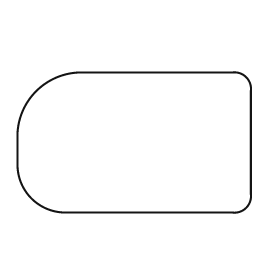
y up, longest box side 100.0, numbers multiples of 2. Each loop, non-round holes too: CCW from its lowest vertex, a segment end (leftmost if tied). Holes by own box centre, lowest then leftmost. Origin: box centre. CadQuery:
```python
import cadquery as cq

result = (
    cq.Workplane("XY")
    .moveTo(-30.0, -30.0)
    .lineTo(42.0, -30.0)
    .threePointArc((48.0, -28.0), (50.0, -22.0))
    .lineTo(50.0, 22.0)
    .threePointArc((48.0, 28.0), (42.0, 30.0))
    .lineTo(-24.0, 30.0)
    .threePointArc((-42.0, 22.0), (-50.0, 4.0))
    .lineTo(-50.0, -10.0)
    .threePointArc((-44.0, -24.0), (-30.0, -30.0))
    .close()
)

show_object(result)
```